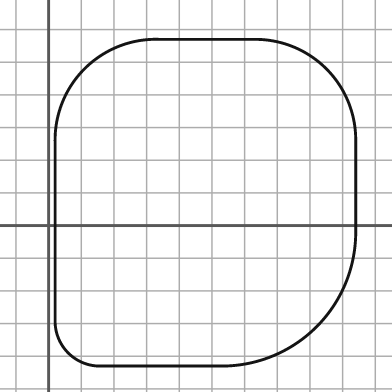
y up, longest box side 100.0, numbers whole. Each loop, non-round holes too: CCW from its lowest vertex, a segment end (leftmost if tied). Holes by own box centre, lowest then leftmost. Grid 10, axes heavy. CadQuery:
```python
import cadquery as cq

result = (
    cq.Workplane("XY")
    .moveTo(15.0, -43.0)
    .lineTo(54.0, -43.0)
    .threePointArc((82.0, -31.0), (94.0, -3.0))
    .lineTo(94.0, 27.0)
    .threePointArc((85.0, 48.0), (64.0, 57.0))
    .lineTo(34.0, 57.0)
    .threePointArc((11.0, 48.0), (2.0, 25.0))
    .lineTo(2.0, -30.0)
    .threePointArc((6.0, -39.0), (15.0, -43.0))
    .close()
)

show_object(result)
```